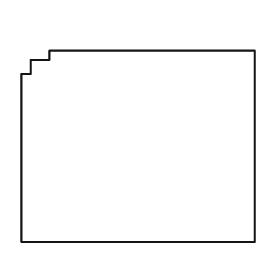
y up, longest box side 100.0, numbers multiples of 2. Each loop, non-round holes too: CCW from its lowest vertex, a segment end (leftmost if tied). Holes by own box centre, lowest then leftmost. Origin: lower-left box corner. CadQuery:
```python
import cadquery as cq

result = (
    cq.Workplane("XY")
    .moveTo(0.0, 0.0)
    .lineTo(100.0, 0.0)
    .lineTo(100.0, 82.0)
    .lineTo(12.0, 82.0)
    .lineTo(12.0, 78.0)
    .lineTo(4.0, 78.0)
    .lineTo(4.0, 72.0)
    .lineTo(0.0, 72.0)
    .close()
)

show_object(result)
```